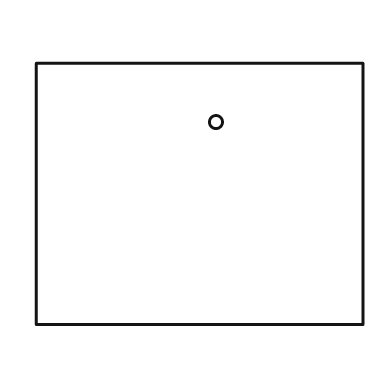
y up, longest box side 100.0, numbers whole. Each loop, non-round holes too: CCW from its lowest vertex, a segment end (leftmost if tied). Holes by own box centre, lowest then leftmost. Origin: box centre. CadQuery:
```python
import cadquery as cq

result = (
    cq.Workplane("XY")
    .moveTo(-50.0, -40.0)
    .lineTo(50.0, -40.0)
    .lineTo(50.0, 40.0)
    .lineTo(-50.0, 40.0)
    .close()
    .moveTo(5.0, 22.0)
    .circle(2.0)
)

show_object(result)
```